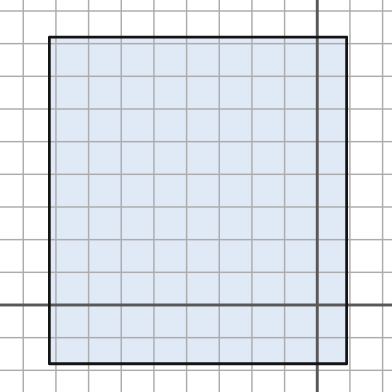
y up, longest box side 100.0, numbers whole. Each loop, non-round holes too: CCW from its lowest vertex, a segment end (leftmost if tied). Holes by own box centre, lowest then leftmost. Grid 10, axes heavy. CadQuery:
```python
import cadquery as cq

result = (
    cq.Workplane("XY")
    .moveTo(-82.0, -18.0)
    .lineTo(9.0, -18.0)
    .lineTo(9.0, 82.0)
    .lineTo(-82.0, 82.0)
    .close()
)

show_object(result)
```